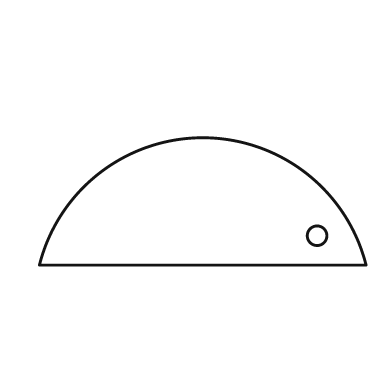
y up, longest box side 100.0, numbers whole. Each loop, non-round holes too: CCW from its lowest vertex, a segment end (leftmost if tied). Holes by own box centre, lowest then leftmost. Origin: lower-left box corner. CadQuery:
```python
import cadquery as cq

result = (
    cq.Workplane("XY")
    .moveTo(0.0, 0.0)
    .lineTo(100.0, 0.0)
    .threePointArc((50.0, 39.0), (0.0, 0.0))
    .close()
    .moveTo(85.0, 9.0)
    .circle(3.0)
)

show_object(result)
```